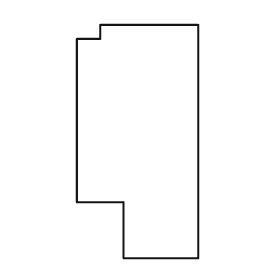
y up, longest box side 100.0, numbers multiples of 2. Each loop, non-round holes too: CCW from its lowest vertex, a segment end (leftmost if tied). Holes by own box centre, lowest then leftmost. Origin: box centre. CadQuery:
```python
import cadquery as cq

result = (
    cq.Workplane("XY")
    .moveTo(-6.0, -50.0)
    .lineTo(26.0, -50.0)
    .lineTo(26.0, 50.0)
    .lineTo(-16.0, 50.0)
    .lineTo(-16.0, 44.0)
    .lineTo(-26.0, 44.0)
    .lineTo(-26.0, -26.0)
    .lineTo(-6.0, -26.0)
    .close()
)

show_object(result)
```